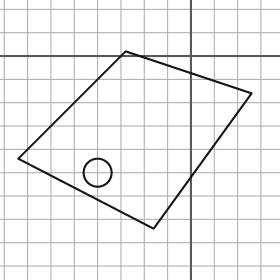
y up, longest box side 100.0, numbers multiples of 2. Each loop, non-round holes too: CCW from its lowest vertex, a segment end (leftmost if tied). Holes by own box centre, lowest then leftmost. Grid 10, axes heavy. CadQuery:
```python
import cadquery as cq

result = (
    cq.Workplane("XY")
    .moveTo(-16.0, -74.0)
    .lineTo(26.0, -16.0)
    .lineTo(-28.0, 2.0)
    .lineTo(-74.0, -44.0)
    .close()
    .moveTo(-40.0, -50.0)
    .circle(6.0)
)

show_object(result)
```